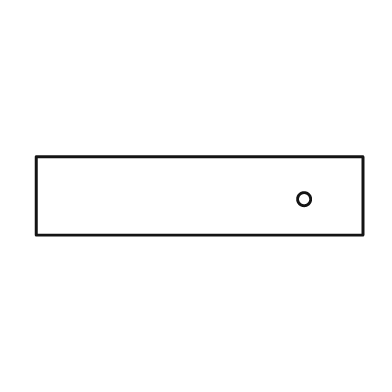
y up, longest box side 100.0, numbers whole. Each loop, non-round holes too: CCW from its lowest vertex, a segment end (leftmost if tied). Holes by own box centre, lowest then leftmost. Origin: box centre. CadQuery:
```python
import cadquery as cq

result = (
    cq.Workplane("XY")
    .moveTo(-50.0, -12.0)
    .lineTo(50.0, -12.0)
    .lineTo(50.0, 12.0)
    .lineTo(-50.0, 12.0)
    .close()
    .moveTo(32.0, -1.0)
    .circle(2.0)
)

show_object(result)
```